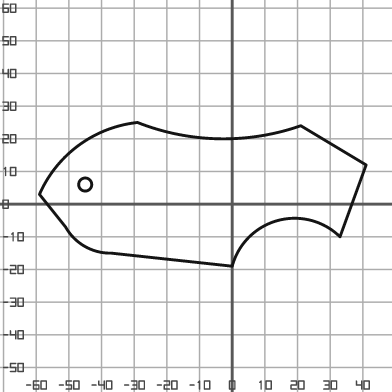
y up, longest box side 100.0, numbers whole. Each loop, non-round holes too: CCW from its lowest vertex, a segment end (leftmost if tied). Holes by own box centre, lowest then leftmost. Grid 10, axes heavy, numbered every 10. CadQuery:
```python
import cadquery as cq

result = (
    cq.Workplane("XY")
    .moveTo(0.0, -19.0)
    .threePointArc((14.0, -5.0), (33.0, -10.0))
    .lineTo(41.0, 12.0)
    .lineTo(21.0, 24.0)
    .threePointArc((-4.0, 20.0), (-29.0, 25.0))
    .threePointArc((-47.0, 18.0), (-59.0, 3.0))
    .lineTo(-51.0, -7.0)
    .threePointArc((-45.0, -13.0), (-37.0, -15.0))
    .close()
    .moveTo(-45.0, 6.0)
    .circle(2.0)
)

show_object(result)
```